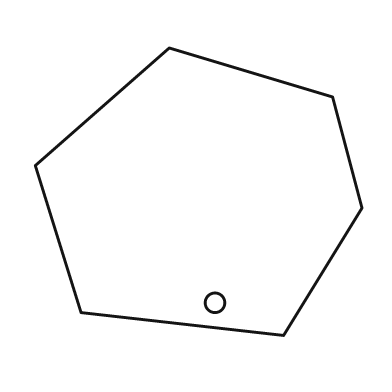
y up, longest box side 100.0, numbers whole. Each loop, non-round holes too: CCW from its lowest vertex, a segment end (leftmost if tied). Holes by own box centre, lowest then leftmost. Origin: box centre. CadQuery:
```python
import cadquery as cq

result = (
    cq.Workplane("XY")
    .moveTo(26.0, -44.0)
    .lineTo(50.0, -5.0)
    .lineTo(41.0, 29.0)
    .lineTo(-9.0, 44.0)
    .lineTo(-50.0, 8.0)
    .lineTo(-36.0, -37.0)
    .close()
    .moveTo(5.0, -34.0)
    .circle(3.0)
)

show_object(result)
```